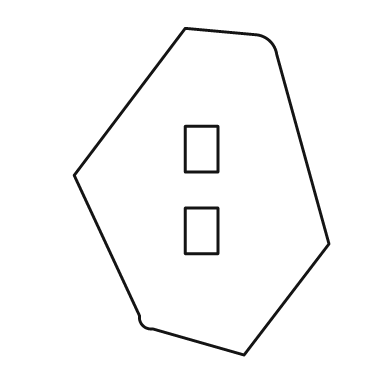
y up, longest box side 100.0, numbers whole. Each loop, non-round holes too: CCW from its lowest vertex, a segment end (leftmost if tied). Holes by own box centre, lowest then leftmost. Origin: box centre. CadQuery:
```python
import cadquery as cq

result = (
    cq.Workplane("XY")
    .moveTo(13.0, -50.0)
    .lineTo(39.0, -16.0)
    .lineTo(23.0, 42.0)
    .threePointArc((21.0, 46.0), (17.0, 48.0))
    .lineTo(-5.0, 50.0)
    .lineTo(-39.0, 5.0)
    .lineTo(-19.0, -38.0)
    .threePointArc((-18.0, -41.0), (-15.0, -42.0))
    .close()
    .moveTo(-5.0, -19.0)
    .lineTo(5.0, -19.0)
    .lineTo(5.0, -5.0)
    .lineTo(-5.0, -5.0)
    .close()
    .moveTo(-5.0, 6.0)
    .lineTo(5.0, 6.0)
    .lineTo(5.0, 20.0)
    .lineTo(-5.0, 20.0)
    .close()
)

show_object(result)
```